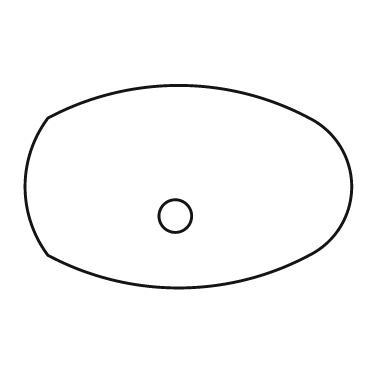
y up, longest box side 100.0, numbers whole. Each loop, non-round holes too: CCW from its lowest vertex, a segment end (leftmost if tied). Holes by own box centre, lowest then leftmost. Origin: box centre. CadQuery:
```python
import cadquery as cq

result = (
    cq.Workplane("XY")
    .moveTo(-43.0, -21.0)
    .threePointArc((-3.0, -31.0), (37.0, -21.0))
    .threePointArc((50.0, 0.0), (37.0, 21.0))
    .threePointArc((-3.0, 31.0), (-43.0, 21.0))
    .threePointArc((-50.0, 0.0), (-43.0, -21.0))
    .close()
    .moveTo(-4.0, -9.0)
    .circle(5.0)
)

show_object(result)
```